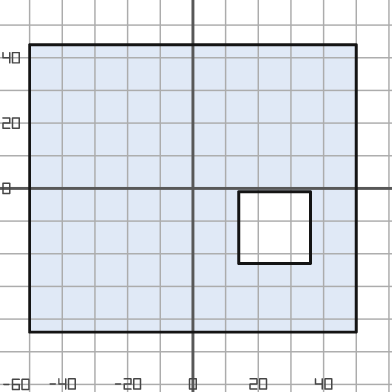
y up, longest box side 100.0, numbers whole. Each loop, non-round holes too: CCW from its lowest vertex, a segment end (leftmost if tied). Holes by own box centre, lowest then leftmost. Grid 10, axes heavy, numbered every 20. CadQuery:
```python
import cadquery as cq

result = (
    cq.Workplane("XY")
    .moveTo(-50.0, -44.0)
    .lineTo(50.0, -44.0)
    .lineTo(50.0, 44.0)
    .lineTo(-50.0, 44.0)
    .close()
    .moveTo(14.0, -23.0)
    .lineTo(36.0, -23.0)
    .lineTo(36.0, -1.0)
    .lineTo(14.0, -1.0)
    .close()
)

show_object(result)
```